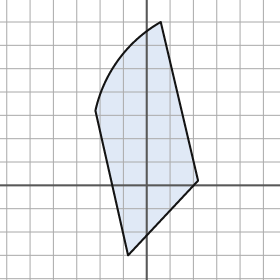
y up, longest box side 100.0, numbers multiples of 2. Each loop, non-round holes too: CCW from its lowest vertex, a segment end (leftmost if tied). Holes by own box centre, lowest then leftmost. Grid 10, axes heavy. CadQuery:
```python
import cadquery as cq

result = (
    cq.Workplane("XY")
    .moveTo(-8.0, -30.0)
    .lineTo(22.0, 2.0)
    .lineTo(6.0, 70.0)
    .threePointArc((-12.0, 54.0), (-22.0, 32.0))
    .close()
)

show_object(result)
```